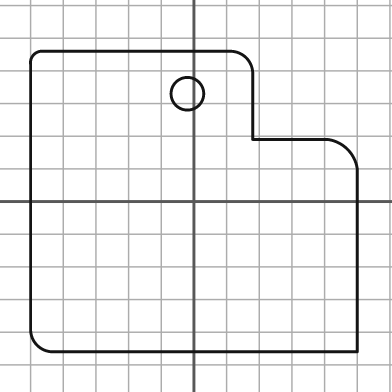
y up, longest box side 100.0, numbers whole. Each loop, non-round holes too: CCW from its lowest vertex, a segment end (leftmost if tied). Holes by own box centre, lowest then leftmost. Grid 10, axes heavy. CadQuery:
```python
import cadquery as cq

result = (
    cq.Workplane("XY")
    .moveTo(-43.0, -46.0)
    .lineTo(50.0, -46.0)
    .lineTo(50.0, 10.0)
    .threePointArc((47.0, 16.0), (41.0, 19.0))
    .lineTo(18.0, 19.0)
    .lineTo(18.0, 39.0)
    .threePointArc((16.0, 44.0), (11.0, 46.0))
    .lineTo(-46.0, 46.0)
    .threePointArc((-49.0, 45.0), (-50.0, 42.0))
    .lineTo(-50.0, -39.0)
    .threePointArc((-48.0, -44.0), (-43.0, -46.0))
    .close()
    .moveTo(-2.0, 33.0)
    .circle(5.0)
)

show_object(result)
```